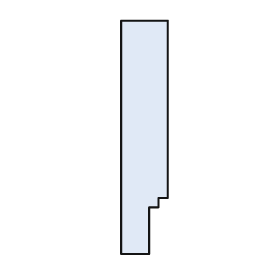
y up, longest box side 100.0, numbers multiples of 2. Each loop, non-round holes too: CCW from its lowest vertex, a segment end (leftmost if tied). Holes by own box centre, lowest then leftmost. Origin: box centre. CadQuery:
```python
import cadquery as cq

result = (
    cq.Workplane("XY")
    .moveTo(-10.0, -50.0)
    .lineTo(2.0, -50.0)
    .lineTo(2.0, -30.0)
    .lineTo(6.0, -30.0)
    .lineTo(6.0, -26.0)
    .lineTo(10.0, -26.0)
    .lineTo(10.0, 50.0)
    .lineTo(-10.0, 50.0)
    .close()
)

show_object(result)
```